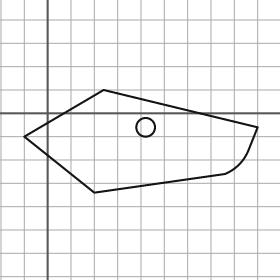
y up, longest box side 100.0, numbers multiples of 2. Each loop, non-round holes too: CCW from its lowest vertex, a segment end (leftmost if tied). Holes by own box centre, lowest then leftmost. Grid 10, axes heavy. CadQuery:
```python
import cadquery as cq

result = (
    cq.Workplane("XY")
    .moveTo(20.0, -34.0)
    .lineTo(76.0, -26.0)
    .threePointArc((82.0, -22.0), (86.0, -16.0))
    .lineTo(90.0, -6.0)
    .lineTo(24.0, 10.0)
    .lineTo(-10.0, -10.0)
    .close()
    .moveTo(42.0, -6.0)
    .circle(4.0)
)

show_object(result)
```